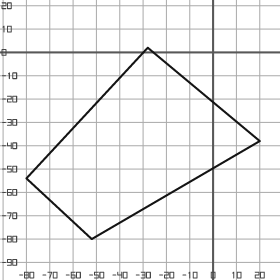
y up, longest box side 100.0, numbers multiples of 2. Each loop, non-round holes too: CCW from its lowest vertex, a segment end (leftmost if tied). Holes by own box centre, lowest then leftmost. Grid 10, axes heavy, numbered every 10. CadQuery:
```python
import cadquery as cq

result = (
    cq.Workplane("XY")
    .moveTo(-52.0, -80.0)
    .lineTo(20.0, -38.0)
    .lineTo(-28.0, 2.0)
    .lineTo(-80.0, -54.0)
    .close()
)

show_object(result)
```